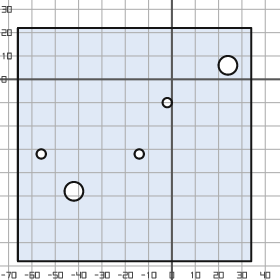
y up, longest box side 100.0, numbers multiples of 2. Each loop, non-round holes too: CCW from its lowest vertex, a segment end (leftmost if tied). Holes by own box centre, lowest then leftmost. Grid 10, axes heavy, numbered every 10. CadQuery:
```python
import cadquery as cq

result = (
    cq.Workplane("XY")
    .moveTo(-66.0, -78.0)
    .lineTo(34.0, -78.0)
    .lineTo(34.0, 22.0)
    .lineTo(-66.0, 22.0)
    .close()
    .moveTo(-42.0, -48.0)
    .circle(4.0)
    .moveTo(-56.0, -32.0)
    .circle(2.0)
    .moveTo(-14.0, -32.0)
    .circle(2.0)
    .moveTo(-2.0, -10.0)
    .circle(2.0)
    .moveTo(24.0, 6.0)
    .circle(4.0)
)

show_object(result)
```